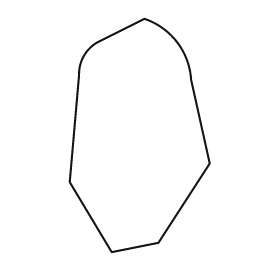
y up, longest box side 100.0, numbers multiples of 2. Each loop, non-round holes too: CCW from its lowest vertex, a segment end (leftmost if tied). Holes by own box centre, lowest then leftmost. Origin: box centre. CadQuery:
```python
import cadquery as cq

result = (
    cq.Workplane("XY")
    .moveTo(-12.0, -50.0)
    .lineTo(8.0, -46.0)
    .lineTo(30.0, -12.0)
    .lineTo(22.0, 24.0)
    .threePointArc((16.0, 40.0), (2.0, 50.0))
    .lineTo(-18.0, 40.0)
    .threePointArc((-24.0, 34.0), (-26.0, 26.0))
    .lineTo(-30.0, -20.0)
    .close()
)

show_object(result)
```